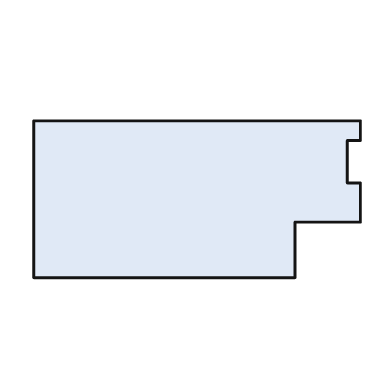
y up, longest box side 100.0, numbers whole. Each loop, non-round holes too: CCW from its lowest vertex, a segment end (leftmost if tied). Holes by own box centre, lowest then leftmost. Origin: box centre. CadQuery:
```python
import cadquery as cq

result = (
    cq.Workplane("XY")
    .moveTo(-50.0, -24.0)
    .lineTo(30.0, -24.0)
    .lineTo(30.0, -7.0)
    .lineTo(50.0, -7.0)
    .lineTo(50.0, 5.0)
    .lineTo(46.0, 5.0)
    .lineTo(46.0, 18.0)
    .lineTo(50.0, 18.0)
    .lineTo(50.0, 24.0)
    .lineTo(-50.0, 24.0)
    .close()
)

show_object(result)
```